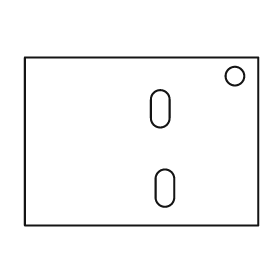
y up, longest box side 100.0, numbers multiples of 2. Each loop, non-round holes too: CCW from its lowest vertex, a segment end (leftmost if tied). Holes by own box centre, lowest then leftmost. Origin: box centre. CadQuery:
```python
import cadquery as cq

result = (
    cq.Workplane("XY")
    .moveTo(-50.0, -36.0)
    .lineTo(50.0, -36.0)
    .lineTo(50.0, 36.0)
    .lineTo(-50.0, 36.0)
    .close()
    .moveTo(6.0, -24.0)
    .threePointArc((10.0, -28.0), (14.0, -24.0))
    .lineTo(14.0, -16.0)
    .threePointArc((10.0, -12.0), (6.0, -16.0))
    .close()
    .moveTo(4.0, 10.0)
    .threePointArc((8.0, 6.0), (12.0, 10.0))
    .lineTo(12.0, 18.0)
    .threePointArc((8.0, 22.0), (4.0, 18.0))
    .close()
    .moveTo(40.0, 28.0)
    .circle(4.0)
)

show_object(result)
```